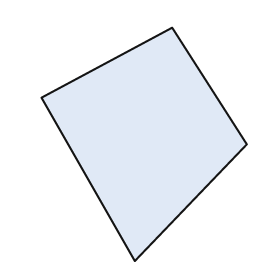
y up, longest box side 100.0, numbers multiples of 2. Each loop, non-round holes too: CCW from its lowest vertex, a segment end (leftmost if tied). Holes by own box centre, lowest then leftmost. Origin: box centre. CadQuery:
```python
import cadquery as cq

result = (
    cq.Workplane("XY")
    .moveTo(-4.0, -50.0)
    .lineTo(44.0, 0.0)
    .lineTo(12.0, 50.0)
    .lineTo(-44.0, 20.0)
    .close()
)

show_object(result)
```